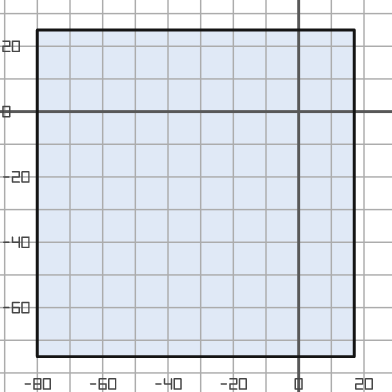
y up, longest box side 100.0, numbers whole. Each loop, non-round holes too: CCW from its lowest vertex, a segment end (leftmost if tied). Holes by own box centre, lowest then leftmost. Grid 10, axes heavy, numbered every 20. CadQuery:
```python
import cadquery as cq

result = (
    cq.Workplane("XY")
    .moveTo(-80.0, -75.0)
    .lineTo(17.0, -75.0)
    .lineTo(17.0, 25.0)
    .lineTo(-80.0, 25.0)
    .close()
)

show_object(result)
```